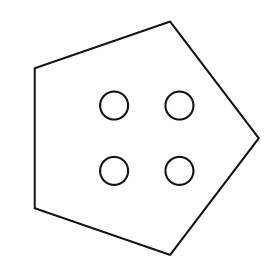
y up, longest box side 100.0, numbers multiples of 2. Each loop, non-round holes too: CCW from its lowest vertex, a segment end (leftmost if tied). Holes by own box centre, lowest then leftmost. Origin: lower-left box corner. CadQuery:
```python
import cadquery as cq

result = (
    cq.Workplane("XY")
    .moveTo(58.0, 0.0)
    .lineTo(96.0, 50.0)
    .lineTo(58.0, 100.0)
    .lineTo(0.0, 80.0)
    .lineTo(0.0, 20.0)
    .close()
    .moveTo(34.0, 36.0)
    .circle(6.0)
    .moveTo(62.0, 36.0)
    .circle(6.0)
    .moveTo(34.0, 64.0)
    .circle(6.0)
    .moveTo(62.0, 64.0)
    .circle(6.0)
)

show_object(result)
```